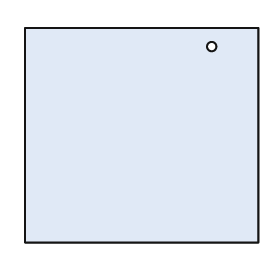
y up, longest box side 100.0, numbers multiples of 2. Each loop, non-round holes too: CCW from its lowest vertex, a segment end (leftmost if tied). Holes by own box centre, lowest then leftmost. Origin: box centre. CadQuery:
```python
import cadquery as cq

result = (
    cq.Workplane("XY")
    .moveTo(-50.0, -46.0)
    .lineTo(50.0, -46.0)
    .lineTo(50.0, 46.0)
    .lineTo(-50.0, 46.0)
    .close()
    .moveTo(30.0, 38.0)
    .circle(2.0)
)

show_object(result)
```